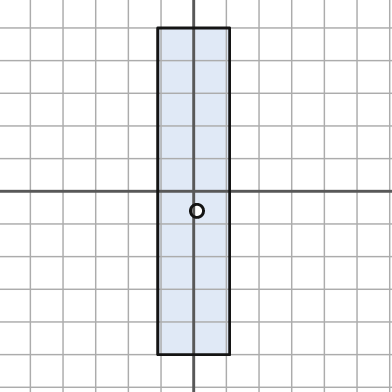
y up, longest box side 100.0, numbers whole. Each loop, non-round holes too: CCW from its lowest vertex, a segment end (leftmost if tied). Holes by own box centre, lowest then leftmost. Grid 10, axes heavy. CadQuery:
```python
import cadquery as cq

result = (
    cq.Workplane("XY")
    .moveTo(-11.0, -50.0)
    .lineTo(11.0, -50.0)
    .lineTo(11.0, 50.0)
    .lineTo(-11.0, 50.0)
    .close()
    .moveTo(1.0, -6.0)
    .circle(2.0)
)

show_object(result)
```